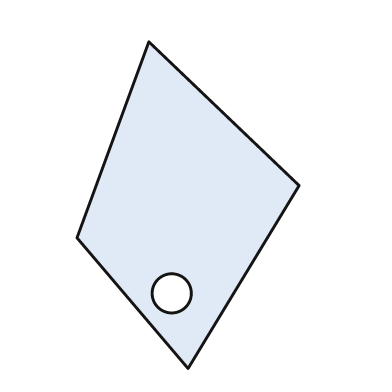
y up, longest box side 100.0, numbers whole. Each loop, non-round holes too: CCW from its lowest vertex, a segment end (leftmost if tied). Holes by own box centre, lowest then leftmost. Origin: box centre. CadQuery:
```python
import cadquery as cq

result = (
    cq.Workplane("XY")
    .moveTo(0.0, -50.0)
    .lineTo(34.0, 6.0)
    .lineTo(-12.0, 50.0)
    .lineTo(-34.0, -10.0)
    .close()
    .moveTo(-5.0, -27.0)
    .circle(6.0)
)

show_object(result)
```